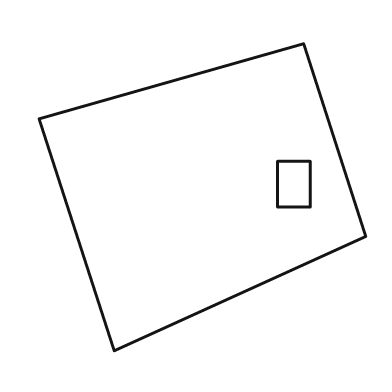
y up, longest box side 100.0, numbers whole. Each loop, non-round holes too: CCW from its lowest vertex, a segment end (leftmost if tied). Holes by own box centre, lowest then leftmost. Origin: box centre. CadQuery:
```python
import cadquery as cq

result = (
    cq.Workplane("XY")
    .moveTo(-27.0, -47.0)
    .lineTo(50.0, -12.0)
    .lineTo(31.0, 47.0)
    .lineTo(-50.0, 24.0)
    .close()
    .moveTo(23.0, -3.0)
    .lineTo(33.0, -3.0)
    .lineTo(33.0, 11.0)
    .lineTo(23.0, 11.0)
    .close()
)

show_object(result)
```